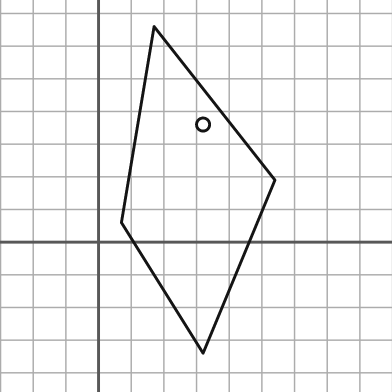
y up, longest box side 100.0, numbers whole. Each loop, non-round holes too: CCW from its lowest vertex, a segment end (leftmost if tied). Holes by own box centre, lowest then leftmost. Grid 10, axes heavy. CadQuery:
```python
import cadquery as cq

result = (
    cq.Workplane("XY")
    .moveTo(32.0, -34.0)
    .lineTo(54.0, 19.0)
    .lineTo(17.0, 66.0)
    .lineTo(7.0, 6.0)
    .close()
    .moveTo(32.0, 36.0)
    .circle(2.0)
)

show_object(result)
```